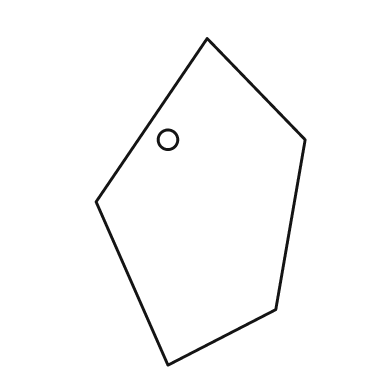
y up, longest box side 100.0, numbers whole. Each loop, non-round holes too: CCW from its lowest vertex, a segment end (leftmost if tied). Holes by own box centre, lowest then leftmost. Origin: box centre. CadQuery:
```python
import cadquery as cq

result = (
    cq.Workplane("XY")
    .moveTo(-10.0, -50.0)
    .lineTo(23.0, -33.0)
    .lineTo(32.0, 19.0)
    .lineTo(2.0, 50.0)
    .lineTo(-32.0, 0.0)
    .close()
    .moveTo(-10.0, 19.0)
    .circle(3.0)
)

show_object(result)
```